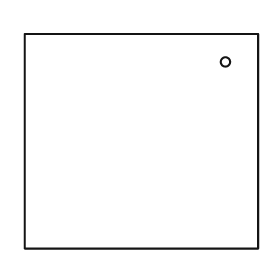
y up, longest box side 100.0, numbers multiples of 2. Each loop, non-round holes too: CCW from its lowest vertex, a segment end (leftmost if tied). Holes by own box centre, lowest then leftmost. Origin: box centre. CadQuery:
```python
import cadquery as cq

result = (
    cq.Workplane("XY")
    .moveTo(-50.0, -46.0)
    .lineTo(50.0, -46.0)
    .lineTo(50.0, 46.0)
    .lineTo(-50.0, 46.0)
    .close()
    .moveTo(36.0, 34.0)
    .circle(2.0)
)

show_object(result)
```